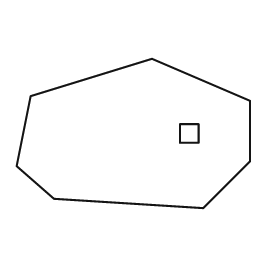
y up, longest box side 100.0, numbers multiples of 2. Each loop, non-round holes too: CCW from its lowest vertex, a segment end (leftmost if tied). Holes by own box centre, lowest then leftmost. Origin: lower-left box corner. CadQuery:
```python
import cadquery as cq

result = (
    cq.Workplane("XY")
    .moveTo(80.0, 0.0)
    .lineTo(100.0, 20.0)
    .lineTo(100.0, 46.0)
    .lineTo(58.0, 64.0)
    .lineTo(6.0, 48.0)
    .lineTo(0.0, 18.0)
    .lineTo(16.0, 4.0)
    .close()
    .moveTo(70.0, 28.0)
    .lineTo(78.0, 28.0)
    .lineTo(78.0, 36.0)
    .lineTo(70.0, 36.0)
    .close()
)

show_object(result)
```